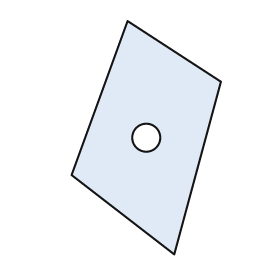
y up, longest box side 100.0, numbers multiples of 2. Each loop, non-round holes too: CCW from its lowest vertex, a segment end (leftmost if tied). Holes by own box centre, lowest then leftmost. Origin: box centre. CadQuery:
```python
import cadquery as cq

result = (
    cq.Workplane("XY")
    .moveTo(12.0, -50.0)
    .lineTo(32.0, 24.0)
    .lineTo(-8.0, 50.0)
    .lineTo(-32.0, -16.0)
    .close()
    .moveTo(0.0, 0.0)
    .circle(6.0)
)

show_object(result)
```